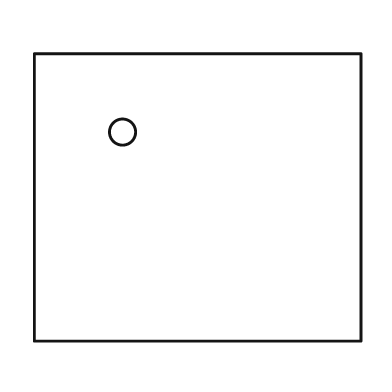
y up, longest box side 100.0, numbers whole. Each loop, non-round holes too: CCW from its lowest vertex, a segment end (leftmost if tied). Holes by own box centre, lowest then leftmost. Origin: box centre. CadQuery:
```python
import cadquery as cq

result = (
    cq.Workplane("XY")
    .moveTo(-50.0, -44.0)
    .lineTo(50.0, -44.0)
    .lineTo(50.0, 44.0)
    .lineTo(-50.0, 44.0)
    .close()
    .moveTo(-23.0, 20.0)
    .circle(4.0)
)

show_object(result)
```